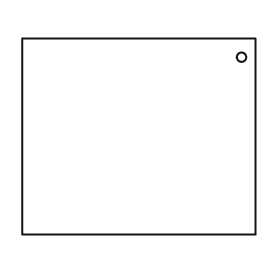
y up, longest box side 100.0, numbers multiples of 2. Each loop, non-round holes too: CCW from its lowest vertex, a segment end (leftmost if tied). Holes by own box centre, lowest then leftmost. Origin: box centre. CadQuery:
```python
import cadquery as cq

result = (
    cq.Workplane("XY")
    .moveTo(-50.0, -42.0)
    .lineTo(50.0, -42.0)
    .lineTo(50.0, 42.0)
    .lineTo(-50.0, 42.0)
    .close()
    .moveTo(44.0, 34.0)
    .circle(2.0)
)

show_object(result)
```